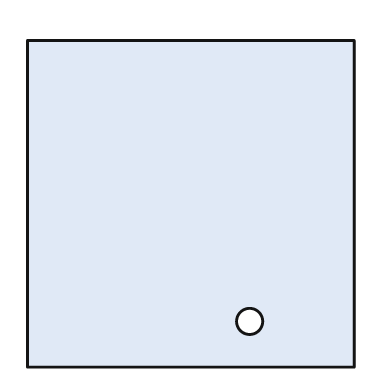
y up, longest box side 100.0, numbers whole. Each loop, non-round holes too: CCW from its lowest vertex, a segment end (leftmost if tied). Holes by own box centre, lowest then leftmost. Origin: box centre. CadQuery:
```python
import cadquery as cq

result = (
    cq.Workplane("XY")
    .moveTo(-50.0, -50.0)
    .lineTo(50.0, -50.0)
    .lineTo(50.0, 50.0)
    .lineTo(-50.0, 50.0)
    .close()
    .moveTo(18.0, -36.0)
    .circle(4.0)
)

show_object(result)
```